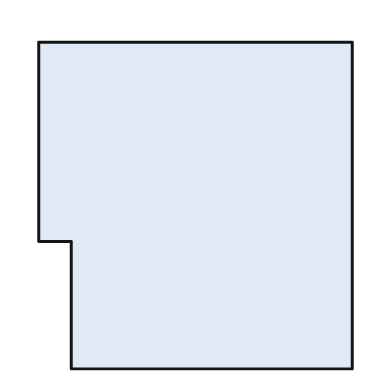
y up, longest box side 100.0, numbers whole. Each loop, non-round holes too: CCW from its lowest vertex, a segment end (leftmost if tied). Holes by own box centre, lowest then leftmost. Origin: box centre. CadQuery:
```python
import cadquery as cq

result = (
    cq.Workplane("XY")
    .moveTo(-38.0, -50.0)
    .lineTo(48.0, -50.0)
    .lineTo(48.0, 50.0)
    .lineTo(-48.0, 50.0)
    .lineTo(-48.0, -11.0)
    .lineTo(-38.0, -11.0)
    .close()
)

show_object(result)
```